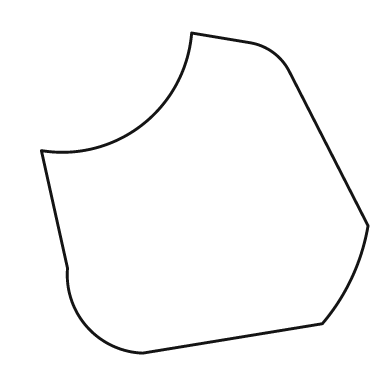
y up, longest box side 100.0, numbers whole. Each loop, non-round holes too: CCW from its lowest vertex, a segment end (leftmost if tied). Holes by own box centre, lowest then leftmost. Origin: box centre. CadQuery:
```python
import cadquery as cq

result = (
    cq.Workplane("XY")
    .moveTo(-19.0, -49.0)
    .lineTo(36.0, -40.0)
    .threePointArc((45.0, -26.0), (50.0, -10.0))
    .lineTo(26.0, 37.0)
    .threePointArc((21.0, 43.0), (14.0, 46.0))
    .lineTo(-4.0, 49.0)
    .threePointArc((-19.0, 21.0), (-50.0, 13.0))
    .lineTo(-42.0, -23.0)
    .threePointArc((-36.0, -41.0), (-19.0, -49.0))
    .close()
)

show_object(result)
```